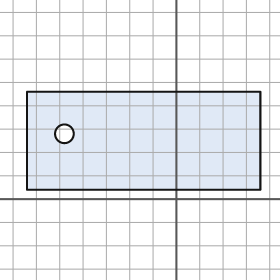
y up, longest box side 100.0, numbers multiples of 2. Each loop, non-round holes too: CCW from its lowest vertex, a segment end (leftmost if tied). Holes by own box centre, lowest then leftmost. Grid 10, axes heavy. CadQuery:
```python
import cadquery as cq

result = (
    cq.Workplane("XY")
    .moveTo(-64.0, 4.0)
    .lineTo(36.0, 4.0)
    .lineTo(36.0, 46.0)
    .lineTo(-64.0, 46.0)
    .close()
    .moveTo(-48.0, 28.0)
    .circle(4.0)
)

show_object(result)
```